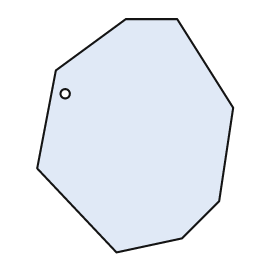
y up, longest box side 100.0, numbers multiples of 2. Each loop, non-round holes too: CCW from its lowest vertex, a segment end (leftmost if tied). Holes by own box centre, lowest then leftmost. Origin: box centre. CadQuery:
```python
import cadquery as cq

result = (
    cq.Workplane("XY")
    .moveTo(-8.0, -50.0)
    .lineTo(20.0, -44.0)
    .lineTo(36.0, -28.0)
    .lineTo(42.0, 12.0)
    .lineTo(18.0, 50.0)
    .lineTo(-4.0, 50.0)
    .lineTo(-34.0, 28.0)
    .lineTo(-42.0, -14.0)
    .close()
    .moveTo(-30.0, 18.0)
    .circle(2.0)
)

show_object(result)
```